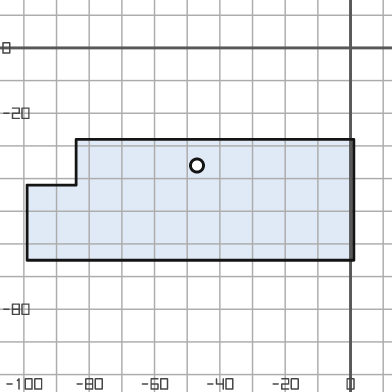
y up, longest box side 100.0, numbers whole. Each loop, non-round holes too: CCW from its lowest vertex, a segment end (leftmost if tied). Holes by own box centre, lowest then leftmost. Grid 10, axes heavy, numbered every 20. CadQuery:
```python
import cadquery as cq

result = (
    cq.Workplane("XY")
    .moveTo(-99.0, -65.0)
    .lineTo(1.0, -65.0)
    .lineTo(1.0, -28.0)
    .lineTo(-84.0, -28.0)
    .lineTo(-84.0, -42.0)
    .lineTo(-99.0, -42.0)
    .close()
    .moveTo(-47.0, -36.0)
    .circle(2.0)
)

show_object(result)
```